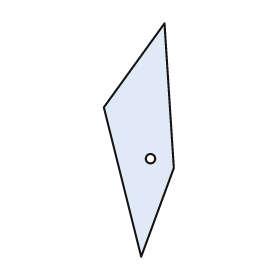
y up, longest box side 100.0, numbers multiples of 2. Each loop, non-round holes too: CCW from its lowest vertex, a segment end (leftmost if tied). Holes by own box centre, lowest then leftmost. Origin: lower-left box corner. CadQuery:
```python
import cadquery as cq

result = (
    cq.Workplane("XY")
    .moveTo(16.0, 0.0)
    .lineTo(30.0, 38.0)
    .lineTo(26.0, 100.0)
    .lineTo(0.0, 64.0)
    .close()
    .moveTo(20.0, 42.0)
    .circle(2.0)
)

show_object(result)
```